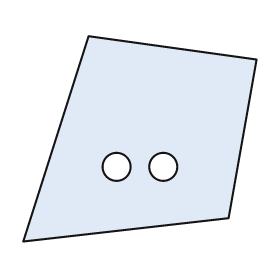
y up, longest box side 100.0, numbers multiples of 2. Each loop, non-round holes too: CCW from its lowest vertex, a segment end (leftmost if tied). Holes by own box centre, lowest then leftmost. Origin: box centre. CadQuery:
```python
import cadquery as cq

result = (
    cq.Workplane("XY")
    .moveTo(-50.0, -44.0)
    .lineTo(38.0, -34.0)
    .lineTo(50.0, 34.0)
    .lineTo(-22.0, 44.0)
    .close()
    .moveTo(-10.0, -12.0)
    .circle(6.0)
    .moveTo(10.0, -12.0)
    .circle(6.0)
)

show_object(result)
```